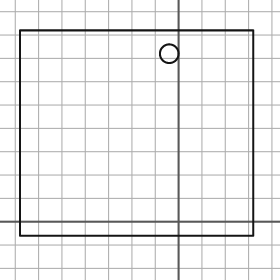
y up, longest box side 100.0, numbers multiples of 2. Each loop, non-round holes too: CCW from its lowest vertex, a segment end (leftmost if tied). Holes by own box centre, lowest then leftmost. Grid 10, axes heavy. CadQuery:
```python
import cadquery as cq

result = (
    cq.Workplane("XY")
    .moveTo(-68.0, -6.0)
    .lineTo(32.0, -6.0)
    .lineTo(32.0, 82.0)
    .lineTo(-68.0, 82.0)
    .close()
    .moveTo(-4.0, 72.0)
    .circle(4.0)
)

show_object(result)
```